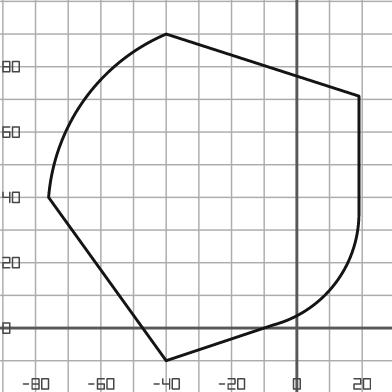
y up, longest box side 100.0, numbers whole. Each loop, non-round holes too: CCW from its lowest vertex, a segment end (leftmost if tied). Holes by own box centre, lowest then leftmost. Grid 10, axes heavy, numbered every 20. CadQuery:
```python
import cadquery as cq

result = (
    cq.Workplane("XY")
    .moveTo(-40.0, -10.0)
    .lineTo(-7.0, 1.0)
    .threePointArc((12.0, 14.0), (19.0, 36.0))
    .lineTo(19.0, 71.0)
    .lineTo(-40.0, 90.0)
    .threePointArc((-65.0, 70.0), (-76.0, 40.0))
    .close()
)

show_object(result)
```